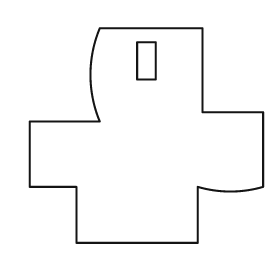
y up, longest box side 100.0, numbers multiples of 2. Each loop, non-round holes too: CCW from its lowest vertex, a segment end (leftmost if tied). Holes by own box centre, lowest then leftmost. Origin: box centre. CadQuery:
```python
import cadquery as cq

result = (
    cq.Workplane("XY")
    .moveTo(-30.0, -46.0)
    .lineTo(22.0, -46.0)
    .lineTo(22.0, -22.0)
    .threePointArc((36.0, -24.0), (50.0, -22.0))
    .lineTo(50.0, 10.0)
    .lineTo(24.0, 10.0)
    .lineTo(24.0, 46.0)
    .lineTo(-20.0, 46.0)
    .threePointArc((-24.0, 26.0), (-20.0, 6.0))
    .lineTo(-50.0, 6.0)
    .lineTo(-50.0, -22.0)
    .lineTo(-30.0, -22.0)
    .close()
    .moveTo(-4.0, 24.0)
    .lineTo(4.0, 24.0)
    .lineTo(4.0, 40.0)
    .lineTo(-4.0, 40.0)
    .close()
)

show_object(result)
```